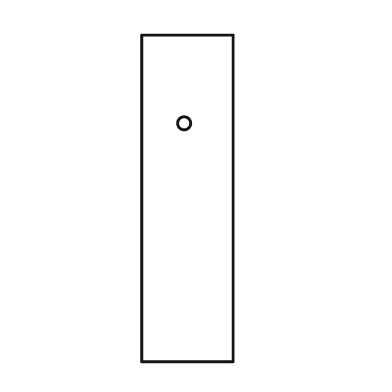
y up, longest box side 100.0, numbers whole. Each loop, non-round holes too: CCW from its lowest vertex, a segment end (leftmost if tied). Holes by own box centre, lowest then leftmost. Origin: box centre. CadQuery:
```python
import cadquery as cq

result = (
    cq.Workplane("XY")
    .moveTo(-14.0, -50.0)
    .lineTo(14.0, -50.0)
    .lineTo(14.0, 50.0)
    .lineTo(-14.0, 50.0)
    .close()
    .moveTo(-1.0, 23.0)
    .circle(2.0)
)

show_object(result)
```